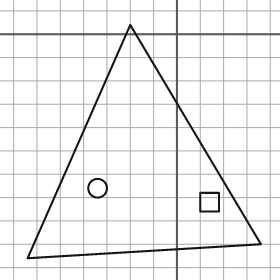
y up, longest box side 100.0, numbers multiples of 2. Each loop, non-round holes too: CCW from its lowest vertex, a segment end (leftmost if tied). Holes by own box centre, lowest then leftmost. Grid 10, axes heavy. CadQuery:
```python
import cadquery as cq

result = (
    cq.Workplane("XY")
    .moveTo(-64.0, -96.0)
    .lineTo(36.0, -90.0)
    .lineTo(-20.0, 4.0)
    .close()
    .moveTo(10.0, -76.0)
    .lineTo(18.0, -76.0)
    .lineTo(18.0, -68.0)
    .lineTo(10.0, -68.0)
    .close()
    .moveTo(-34.0, -66.0)
    .circle(4.0)
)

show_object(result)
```